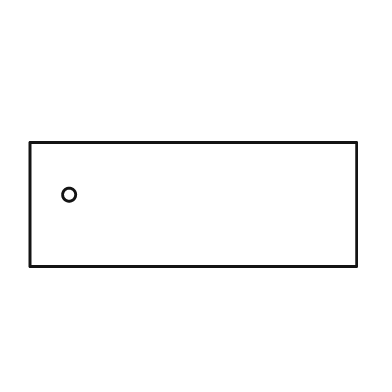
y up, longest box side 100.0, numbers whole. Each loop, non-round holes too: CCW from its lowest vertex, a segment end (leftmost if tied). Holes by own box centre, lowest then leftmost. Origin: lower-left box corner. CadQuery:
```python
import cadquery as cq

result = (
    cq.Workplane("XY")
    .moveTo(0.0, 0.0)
    .lineTo(100.0, 0.0)
    .lineTo(100.0, 38.0)
    .lineTo(0.0, 38.0)
    .close()
    .moveTo(12.0, 22.0)
    .circle(2.0)
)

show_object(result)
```